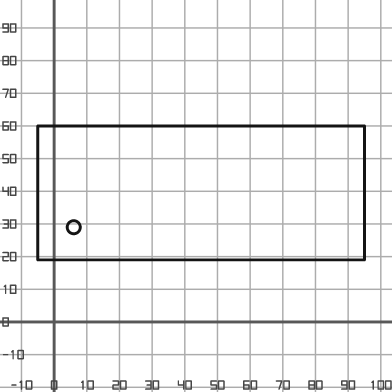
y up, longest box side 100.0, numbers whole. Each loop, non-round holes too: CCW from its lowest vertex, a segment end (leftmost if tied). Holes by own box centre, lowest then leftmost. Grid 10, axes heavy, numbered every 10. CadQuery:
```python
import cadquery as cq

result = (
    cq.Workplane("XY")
    .moveTo(-5.0, 19.0)
    .lineTo(95.0, 19.0)
    .lineTo(95.0, 60.0)
    .lineTo(-5.0, 60.0)
    .close()
    .moveTo(6.0, 29.0)
    .circle(2.0)
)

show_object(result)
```